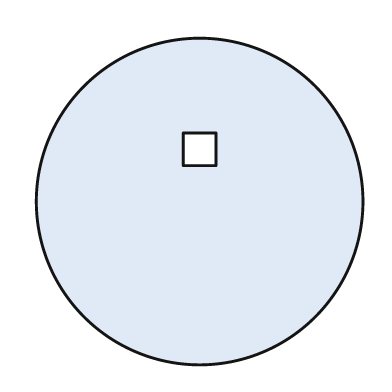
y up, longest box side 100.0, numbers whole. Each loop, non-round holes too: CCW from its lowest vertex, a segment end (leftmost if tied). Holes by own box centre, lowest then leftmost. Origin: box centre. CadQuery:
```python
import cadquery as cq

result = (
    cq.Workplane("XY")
    .moveTo(0.0, 0.0)
    .circle(50.0)
    .moveTo(-5.0, 11.0)
    .lineTo(5.0, 11.0)
    .lineTo(5.0, 21.0)
    .lineTo(-5.0, 21.0)
    .close()
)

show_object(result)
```